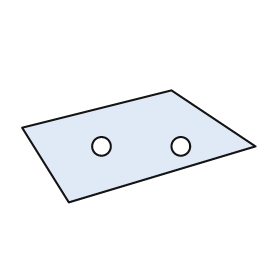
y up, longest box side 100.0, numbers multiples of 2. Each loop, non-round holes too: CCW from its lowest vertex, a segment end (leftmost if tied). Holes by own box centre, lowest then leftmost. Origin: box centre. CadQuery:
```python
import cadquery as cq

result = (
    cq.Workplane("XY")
    .moveTo(-30.0, -24.0)
    .lineTo(50.0, 0.0)
    .lineTo(14.0, 24.0)
    .lineTo(-50.0, 8.0)
    .close()
    .moveTo(-16.0, 0.0)
    .circle(4.0)
    .moveTo(18.0, 0.0)
    .circle(4.0)
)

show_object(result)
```